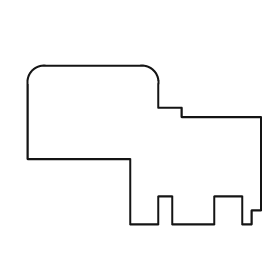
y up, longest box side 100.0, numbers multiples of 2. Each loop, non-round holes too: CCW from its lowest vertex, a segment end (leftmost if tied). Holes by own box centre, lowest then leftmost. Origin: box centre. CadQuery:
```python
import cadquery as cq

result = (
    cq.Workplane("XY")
    .moveTo(-6.0, -34.0)
    .lineTo(6.0, -34.0)
    .lineTo(6.0, -22.0)
    .lineTo(12.0, -22.0)
    .lineTo(12.0, -34.0)
    .lineTo(30.0, -34.0)
    .lineTo(30.0, -22.0)
    .lineTo(42.0, -22.0)
    .lineTo(42.0, -34.0)
    .lineTo(46.0, -34.0)
    .lineTo(46.0, -28.0)
    .lineTo(50.0, -28.0)
    .lineTo(50.0, 12.0)
    .lineTo(16.0, 12.0)
    .lineTo(16.0, 16.0)
    .lineTo(6.0, 16.0)
    .lineTo(6.0, 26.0)
    .threePointArc((4.0, 32.0), (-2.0, 34.0))
    .lineTo(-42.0, 34.0)
    .threePointArc((-48.0, 32.0), (-50.0, 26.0))
    .lineTo(-50.0, -6.0)
    .lineTo(-6.0, -6.0)
    .close()
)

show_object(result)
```